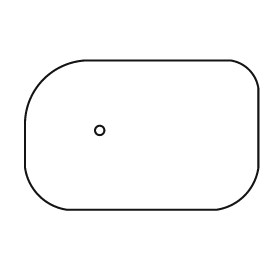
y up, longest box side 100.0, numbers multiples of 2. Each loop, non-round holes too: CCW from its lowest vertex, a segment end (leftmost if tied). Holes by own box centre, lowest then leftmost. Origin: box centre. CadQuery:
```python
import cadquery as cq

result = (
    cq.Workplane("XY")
    .moveTo(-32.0, -32.0)
    .lineTo(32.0, -32.0)
    .threePointArc((44.0, -26.0), (50.0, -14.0))
    .lineTo(50.0, 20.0)
    .threePointArc((46.0, 28.0), (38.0, 32.0))
    .lineTo(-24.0, 32.0)
    .threePointArc((-42.0, 24.0), (-50.0, 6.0))
    .lineTo(-50.0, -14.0)
    .threePointArc((-44.0, -26.0), (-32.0, -32.0))
    .close()
    .moveTo(-18.0, 2.0)
    .circle(2.0)
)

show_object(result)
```